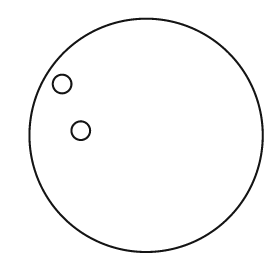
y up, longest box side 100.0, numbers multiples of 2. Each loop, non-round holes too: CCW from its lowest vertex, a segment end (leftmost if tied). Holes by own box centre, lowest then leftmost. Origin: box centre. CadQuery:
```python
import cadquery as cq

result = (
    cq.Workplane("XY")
    .moveTo(0.0, 0.0)
    .circle(50.0)
    .moveTo(-28.0, 2.0)
    .circle(4.0)
    .moveTo(-36.0, 22.0)
    .circle(4.0)
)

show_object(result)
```